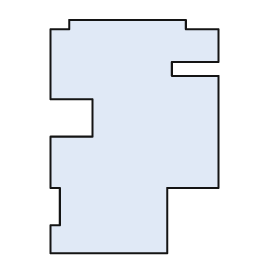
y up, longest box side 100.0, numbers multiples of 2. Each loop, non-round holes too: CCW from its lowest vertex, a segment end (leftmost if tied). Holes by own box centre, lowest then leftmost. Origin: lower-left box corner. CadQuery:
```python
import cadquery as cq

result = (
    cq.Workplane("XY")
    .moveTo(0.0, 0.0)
    .lineTo(50.0, 0.0)
    .lineTo(50.0, 28.0)
    .lineTo(72.0, 28.0)
    .lineTo(72.0, 76.0)
    .lineTo(52.0, 76.0)
    .lineTo(52.0, 82.0)
    .lineTo(72.0, 82.0)
    .lineTo(72.0, 96.0)
    .lineTo(58.0, 96.0)
    .lineTo(58.0, 100.0)
    .lineTo(8.0, 100.0)
    .lineTo(8.0, 96.0)
    .lineTo(0.0, 96.0)
    .lineTo(0.0, 66.0)
    .lineTo(18.0, 66.0)
    .lineTo(18.0, 50.0)
    .lineTo(0.0, 50.0)
    .lineTo(0.0, 28.0)
    .lineTo(4.0, 28.0)
    .lineTo(4.0, 12.0)
    .lineTo(0.0, 12.0)
    .close()
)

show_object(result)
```